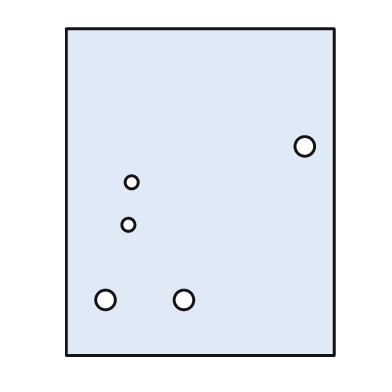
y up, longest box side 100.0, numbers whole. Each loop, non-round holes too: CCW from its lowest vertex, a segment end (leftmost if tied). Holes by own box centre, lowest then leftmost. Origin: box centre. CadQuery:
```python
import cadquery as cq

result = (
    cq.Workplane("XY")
    .moveTo(-41.0, -50.0)
    .lineTo(41.0, -50.0)
    .lineTo(41.0, 50.0)
    .lineTo(-41.0, 50.0)
    .close()
    .moveTo(-29.0, -33.0)
    .circle(3.0)
    .moveTo(-5.0, -33.0)
    .circle(3.0)
    .moveTo(-22.0, -10.0)
    .circle(2.0)
    .moveTo(-21.0, 3.0)
    .circle(2.0)
    .moveTo(32.0, 14.0)
    .circle(3.0)
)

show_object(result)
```